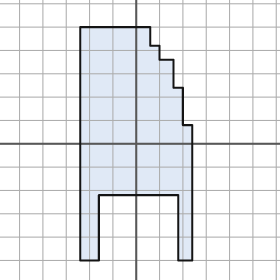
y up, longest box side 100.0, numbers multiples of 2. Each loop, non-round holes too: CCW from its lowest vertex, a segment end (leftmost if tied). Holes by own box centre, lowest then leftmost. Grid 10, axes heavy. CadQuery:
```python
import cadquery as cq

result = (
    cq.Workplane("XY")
    .moveTo(-24.0, -50.0)
    .lineTo(-16.0, -50.0)
    .lineTo(-16.0, -22.0)
    .lineTo(18.0, -22.0)
    .lineTo(18.0, -50.0)
    .lineTo(24.0, -50.0)
    .lineTo(24.0, 8.0)
    .lineTo(20.0, 8.0)
    .lineTo(20.0, 24.0)
    .lineTo(16.0, 24.0)
    .lineTo(16.0, 36.0)
    .lineTo(10.0, 36.0)
    .lineTo(10.0, 42.0)
    .lineTo(6.0, 42.0)
    .lineTo(6.0, 50.0)
    .lineTo(-24.0, 50.0)
    .close()
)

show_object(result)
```